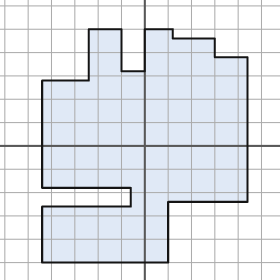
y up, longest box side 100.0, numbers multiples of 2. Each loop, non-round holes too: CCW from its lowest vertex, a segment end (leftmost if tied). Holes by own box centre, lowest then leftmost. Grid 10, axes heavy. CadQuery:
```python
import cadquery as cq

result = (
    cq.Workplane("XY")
    .moveTo(-44.0, -50.0)
    .lineTo(10.0, -50.0)
    .lineTo(10.0, -24.0)
    .lineTo(44.0, -24.0)
    .lineTo(44.0, 38.0)
    .lineTo(30.0, 38.0)
    .lineTo(30.0, 46.0)
    .lineTo(12.0, 46.0)
    .lineTo(12.0, 50.0)
    .lineTo(0.0, 50.0)
    .lineTo(0.0, 32.0)
    .lineTo(-10.0, 32.0)
    .lineTo(-10.0, 50.0)
    .lineTo(-24.0, 50.0)
    .lineTo(-24.0, 28.0)
    .lineTo(-44.0, 28.0)
    .lineTo(-44.0, -18.0)
    .lineTo(-6.0, -18.0)
    .lineTo(-6.0, -26.0)
    .lineTo(-44.0, -26.0)
    .close()
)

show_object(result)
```